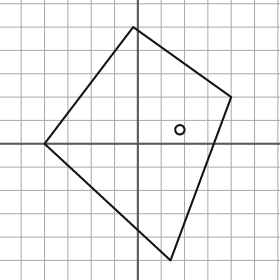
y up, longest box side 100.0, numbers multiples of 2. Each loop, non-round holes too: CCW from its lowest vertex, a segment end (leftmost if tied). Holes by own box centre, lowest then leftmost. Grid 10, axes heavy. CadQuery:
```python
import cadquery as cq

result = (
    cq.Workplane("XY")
    .moveTo(14.0, -50.0)
    .lineTo(40.0, 20.0)
    .lineTo(-2.0, 50.0)
    .lineTo(-40.0, 0.0)
    .close()
    .moveTo(18.0, 6.0)
    .circle(2.0)
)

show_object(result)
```